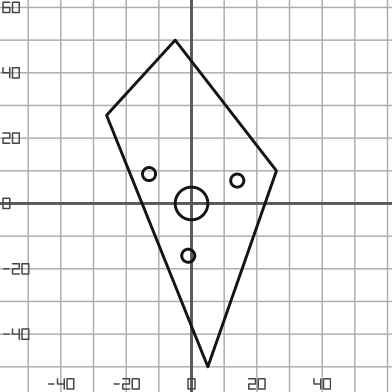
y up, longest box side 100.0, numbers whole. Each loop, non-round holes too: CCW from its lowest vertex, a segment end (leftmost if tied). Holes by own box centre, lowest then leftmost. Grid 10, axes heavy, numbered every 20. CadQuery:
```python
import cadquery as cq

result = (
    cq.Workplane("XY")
    .moveTo(5.0, -50.0)
    .lineTo(26.0, 10.0)
    .lineTo(-5.0, 50.0)
    .lineTo(-26.0, 27.0)
    .close()
    .moveTo(-1.0, -16.0)
    .circle(2.0)
    .moveTo(0.0, 0.0)
    .circle(5.0)
    .moveTo(14.0, 7.0)
    .circle(2.0)
    .moveTo(-13.0, 9.0)
    .circle(2.0)
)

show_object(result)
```